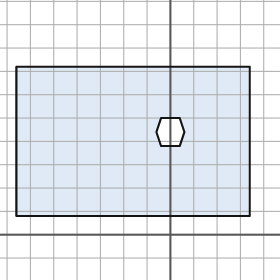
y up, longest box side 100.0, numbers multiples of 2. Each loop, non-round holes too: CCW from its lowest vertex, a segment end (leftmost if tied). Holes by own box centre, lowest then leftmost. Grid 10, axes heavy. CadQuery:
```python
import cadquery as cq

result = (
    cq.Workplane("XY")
    .moveTo(-66.0, 8.0)
    .lineTo(34.0, 8.0)
    .lineTo(34.0, 72.0)
    .lineTo(-66.0, 72.0)
    .close()
    .moveTo(-4.0, 38.0)
    .lineTo(4.0, 38.0)
    .lineTo(6.0, 44.0)
    .lineTo(4.0, 50.0)
    .lineTo(-4.0, 50.0)
    .lineTo(-6.0, 44.0)
    .close()
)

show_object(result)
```